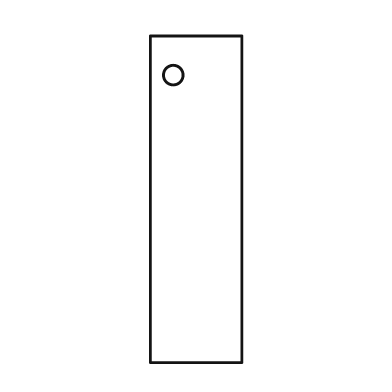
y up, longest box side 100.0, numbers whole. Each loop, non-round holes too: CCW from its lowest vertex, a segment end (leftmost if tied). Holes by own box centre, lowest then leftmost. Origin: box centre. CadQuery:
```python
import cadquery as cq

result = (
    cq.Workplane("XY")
    .moveTo(-14.0, -50.0)
    .lineTo(14.0, -50.0)
    .lineTo(14.0, 50.0)
    .lineTo(-14.0, 50.0)
    .close()
    .moveTo(-7.0, 38.0)
    .circle(3.0)
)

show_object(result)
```